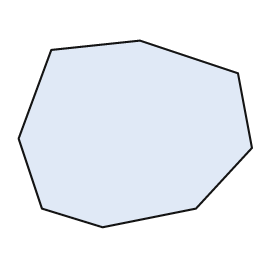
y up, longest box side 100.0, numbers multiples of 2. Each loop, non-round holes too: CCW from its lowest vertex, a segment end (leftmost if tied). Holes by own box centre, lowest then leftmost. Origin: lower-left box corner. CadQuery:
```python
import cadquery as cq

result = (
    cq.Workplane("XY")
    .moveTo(36.0, 0.0)
    .lineTo(76.0, 8.0)
    .lineTo(100.0, 34.0)
    .lineTo(94.0, 66.0)
    .lineTo(52.0, 80.0)
    .lineTo(14.0, 76.0)
    .lineTo(0.0, 38.0)
    .lineTo(10.0, 8.0)
    .close()
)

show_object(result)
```